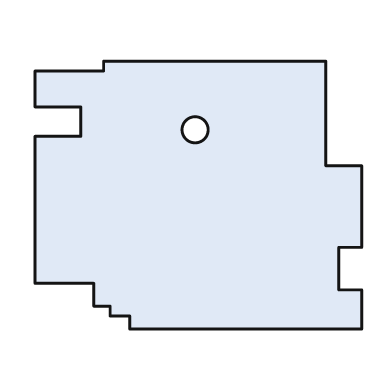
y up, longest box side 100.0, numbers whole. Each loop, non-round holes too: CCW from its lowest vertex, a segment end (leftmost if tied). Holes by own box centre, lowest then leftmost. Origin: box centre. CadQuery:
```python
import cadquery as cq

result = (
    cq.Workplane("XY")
    .moveTo(-21.0, -41.0)
    .lineTo(50.0, -41.0)
    .lineTo(50.0, -29.0)
    .lineTo(43.0, -29.0)
    .lineTo(43.0, -16.0)
    .lineTo(50.0, -16.0)
    .lineTo(50.0, 9.0)
    .lineTo(39.0, 9.0)
    .lineTo(39.0, 41.0)
    .lineTo(-29.0, 41.0)
    .lineTo(-29.0, 38.0)
    .lineTo(-50.0, 38.0)
    .lineTo(-50.0, 27.0)
    .lineTo(-36.0, 27.0)
    .lineTo(-36.0, 18.0)
    .lineTo(-50.0, 18.0)
    .lineTo(-50.0, -27.0)
    .lineTo(-32.0, -27.0)
    .lineTo(-32.0, -34.0)
    .lineTo(-27.0, -34.0)
    .lineTo(-27.0, -37.0)
    .lineTo(-21.0, -37.0)
    .close()
    .moveTo(-1.0, 20.0)
    .circle(4.0)
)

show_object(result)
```